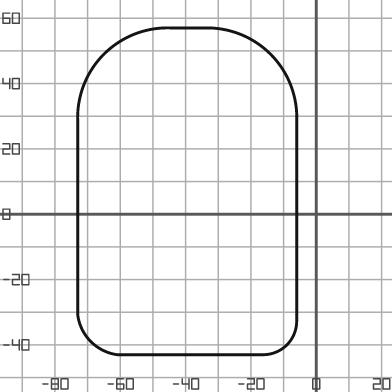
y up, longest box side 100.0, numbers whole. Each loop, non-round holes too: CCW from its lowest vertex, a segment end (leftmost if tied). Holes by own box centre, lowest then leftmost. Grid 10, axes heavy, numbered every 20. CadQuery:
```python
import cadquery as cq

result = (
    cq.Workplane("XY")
    .moveTo(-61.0, -43.0)
    .lineTo(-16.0, -43.0)
    .threePointArc((-9.0, -40.0), (-6.0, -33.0))
    .lineTo(-6.0, 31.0)
    .threePointArc((-14.0, 49.0), (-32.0, 57.0))
    .lineTo(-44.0, 57.0)
    .threePointArc((-65.0, 49.0), (-73.0, 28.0))
    .lineTo(-73.0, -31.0)
    .threePointArc((-69.0, -39.0), (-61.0, -43.0))
    .close()
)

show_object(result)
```